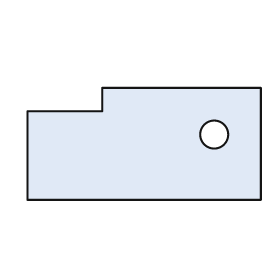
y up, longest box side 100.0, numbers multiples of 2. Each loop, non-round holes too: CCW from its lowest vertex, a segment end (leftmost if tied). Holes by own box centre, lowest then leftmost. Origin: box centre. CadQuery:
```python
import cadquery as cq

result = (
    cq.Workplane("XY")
    .moveTo(-50.0, -24.0)
    .lineTo(50.0, -24.0)
    .lineTo(50.0, 24.0)
    .lineTo(-18.0, 24.0)
    .lineTo(-18.0, 14.0)
    .lineTo(-50.0, 14.0)
    .close()
    .moveTo(30.0, 4.0)
    .circle(6.0)
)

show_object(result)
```